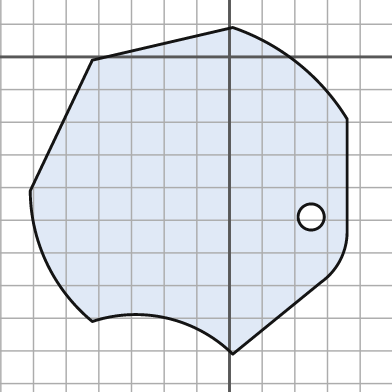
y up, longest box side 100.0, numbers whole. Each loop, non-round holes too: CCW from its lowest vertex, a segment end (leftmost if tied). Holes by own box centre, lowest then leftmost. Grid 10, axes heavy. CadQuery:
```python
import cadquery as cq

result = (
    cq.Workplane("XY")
    .moveTo(1.0, -91.0)
    .lineTo(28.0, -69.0)
    .threePointArc((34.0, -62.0), (36.0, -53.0))
    .lineTo(36.0, -19.0)
    .threePointArc((21.0, -2.0), (1.0, 9.0))
    .lineTo(-42.0, -1.0)
    .lineTo(-61.0, -41.0)
    .threePointArc((-56.0, -63.0), (-42.0, -81.0))
    .threePointArc((-19.0, -80.0), (1.0, -91.0))
    .close()
    .moveTo(25.0, -49.0)
    .circle(4.0)
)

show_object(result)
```